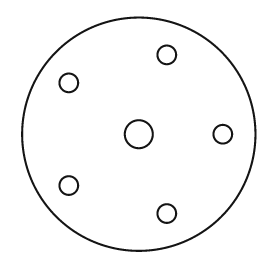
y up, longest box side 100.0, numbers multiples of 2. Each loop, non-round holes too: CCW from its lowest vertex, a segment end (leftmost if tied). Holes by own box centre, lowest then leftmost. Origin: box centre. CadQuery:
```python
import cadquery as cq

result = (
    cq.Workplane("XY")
    .moveTo(0.0, 0.0)
    .circle(50.0)
    .moveTo(12.0, -34.0)
    .circle(4.0)
    .moveTo(-30.0, -22.0)
    .circle(4.0)
    .moveTo(0.0, 0.0)
    .circle(6.0)
    .moveTo(36.0, 0.0)
    .circle(4.0)
    .moveTo(-30.0, 22.0)
    .circle(4.0)
    .moveTo(12.0, 34.0)
    .circle(4.0)
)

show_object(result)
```